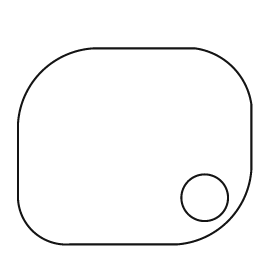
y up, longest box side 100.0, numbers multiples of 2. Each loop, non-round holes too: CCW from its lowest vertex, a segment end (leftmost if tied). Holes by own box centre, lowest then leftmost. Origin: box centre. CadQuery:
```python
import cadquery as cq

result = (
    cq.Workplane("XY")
    .moveTo(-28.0, -42.0)
    .lineTo(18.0, -42.0)
    .threePointArc((40.0, -32.0), (50.0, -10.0))
    .lineTo(50.0, 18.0)
    .threePointArc((42.0, 34.0), (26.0, 42.0))
    .lineTo(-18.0, 42.0)
    .threePointArc((-40.0, 32.0), (-50.0, 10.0))
    .lineTo(-50.0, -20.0)
    .threePointArc((-44.0, -36.0), (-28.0, -42.0))
    .close()
    .moveTo(30.0, -22.0)
    .circle(10.0)
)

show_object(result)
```